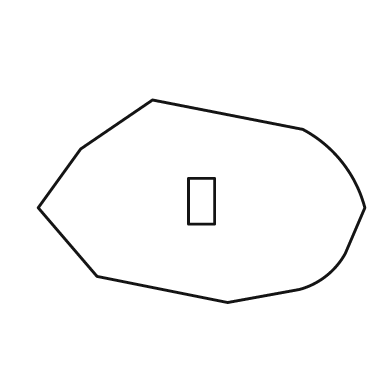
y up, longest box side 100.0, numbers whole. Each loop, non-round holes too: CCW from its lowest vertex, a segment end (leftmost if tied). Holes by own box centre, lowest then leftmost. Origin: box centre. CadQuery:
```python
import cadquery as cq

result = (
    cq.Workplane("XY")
    .moveTo(8.0, -31.0)
    .lineTo(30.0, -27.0)
    .threePointArc((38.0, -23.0), (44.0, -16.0))
    .lineTo(50.0, -2.0)
    .threePointArc((43.0, 12.0), (31.0, 22.0))
    .lineTo(-15.0, 31.0)
    .lineTo(-37.0, 16.0)
    .lineTo(-50.0, -2.0)
    .lineTo(-32.0, -23.0)
    .close()
    .moveTo(-4.0, -7.0)
    .lineTo(4.0, -7.0)
    .lineTo(4.0, 7.0)
    .lineTo(-4.0, 7.0)
    .close()
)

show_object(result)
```